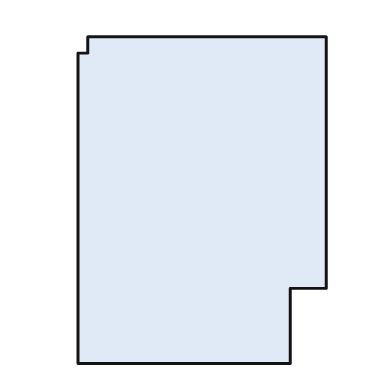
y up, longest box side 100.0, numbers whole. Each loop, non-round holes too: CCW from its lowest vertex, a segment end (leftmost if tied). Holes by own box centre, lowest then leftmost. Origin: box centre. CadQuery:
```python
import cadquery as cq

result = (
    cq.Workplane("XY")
    .moveTo(-38.0, -50.0)
    .lineTo(27.0, -50.0)
    .lineTo(27.0, -27.0)
    .lineTo(38.0, -27.0)
    .lineTo(38.0, 50.0)
    .lineTo(-35.0, 50.0)
    .lineTo(-35.0, 45.0)
    .lineTo(-38.0, 45.0)
    .close()
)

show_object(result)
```